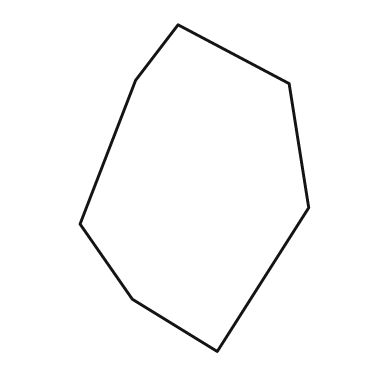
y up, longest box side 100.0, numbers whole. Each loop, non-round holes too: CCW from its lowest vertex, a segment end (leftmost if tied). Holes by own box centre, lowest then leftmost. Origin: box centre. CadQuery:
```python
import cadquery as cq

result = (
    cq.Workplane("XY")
    .moveTo(7.0, -50.0)
    .lineTo(35.0, -6.0)
    .lineTo(29.0, 32.0)
    .lineTo(-5.0, 50.0)
    .lineTo(-18.0, 33.0)
    .lineTo(-35.0, -11.0)
    .lineTo(-19.0, -34.0)
    .close()
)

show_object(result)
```